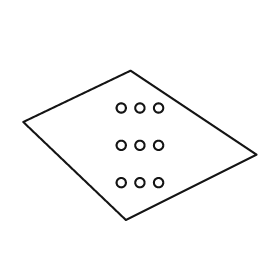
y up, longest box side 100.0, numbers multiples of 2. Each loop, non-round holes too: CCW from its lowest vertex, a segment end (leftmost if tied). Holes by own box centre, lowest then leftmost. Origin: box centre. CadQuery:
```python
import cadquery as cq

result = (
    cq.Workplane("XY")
    .moveTo(-6.0, -32.0)
    .lineTo(50.0, -4.0)
    .lineTo(-4.0, 32.0)
    .lineTo(-50.0, 10.0)
    .close()
    .moveTo(-8.0, -16.0)
    .circle(2.0)
    .moveTo(0.0, -16.0)
    .circle(2.0)
    .moveTo(8.0, -16.0)
    .circle(2.0)
    .moveTo(-8.0, 0.0)
    .circle(2.0)
    .moveTo(0.0, 0.0)
    .circle(2.0)
    .moveTo(8.0, 0.0)
    .circle(2.0)
    .moveTo(-8.0, 16.0)
    .circle(2.0)
    .moveTo(0.0, 16.0)
    .circle(2.0)
    .moveTo(8.0, 16.0)
    .circle(2.0)
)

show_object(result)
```